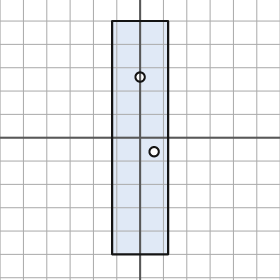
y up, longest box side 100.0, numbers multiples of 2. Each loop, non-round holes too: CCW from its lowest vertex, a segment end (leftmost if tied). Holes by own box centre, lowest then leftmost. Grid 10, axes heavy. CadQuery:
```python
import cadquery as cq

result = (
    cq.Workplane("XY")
    .moveTo(-12.0, -50.0)
    .lineTo(12.0, -50.0)
    .lineTo(12.0, 50.0)
    .lineTo(-12.0, 50.0)
    .close()
    .moveTo(6.0, -6.0)
    .circle(2.0)
    .moveTo(0.0, 26.0)
    .circle(2.0)
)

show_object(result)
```